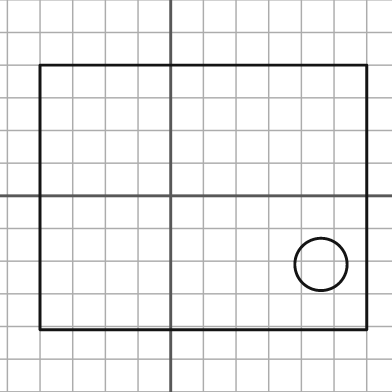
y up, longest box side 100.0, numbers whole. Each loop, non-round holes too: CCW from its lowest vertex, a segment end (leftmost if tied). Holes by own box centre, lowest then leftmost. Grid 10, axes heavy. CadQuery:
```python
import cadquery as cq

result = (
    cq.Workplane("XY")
    .moveTo(-40.0, -41.0)
    .lineTo(60.0, -41.0)
    .lineTo(60.0, 40.0)
    .lineTo(-40.0, 40.0)
    .close()
    .moveTo(46.0, -21.0)
    .circle(8.0)
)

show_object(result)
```